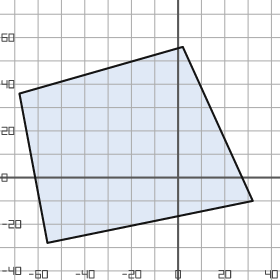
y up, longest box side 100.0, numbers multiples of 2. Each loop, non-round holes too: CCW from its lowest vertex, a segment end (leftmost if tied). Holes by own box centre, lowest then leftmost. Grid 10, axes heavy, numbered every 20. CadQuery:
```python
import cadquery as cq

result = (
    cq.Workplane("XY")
    .moveTo(-56.0, -28.0)
    .lineTo(32.0, -10.0)
    .lineTo(2.0, 56.0)
    .lineTo(-68.0, 36.0)
    .close()
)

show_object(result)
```